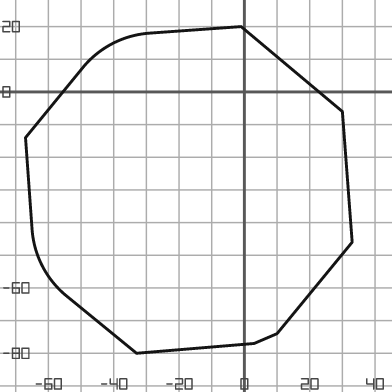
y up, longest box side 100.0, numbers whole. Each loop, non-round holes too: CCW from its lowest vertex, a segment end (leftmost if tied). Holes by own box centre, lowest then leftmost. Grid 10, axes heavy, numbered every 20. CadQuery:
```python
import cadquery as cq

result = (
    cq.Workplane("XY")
    .moveTo(-33.0, -80.0)
    .lineTo(3.0, -77.0)
    .lineTo(10.0, -74.0)
    .lineTo(33.0, -46.0)
    .lineTo(30.0, -6.0)
    .lineTo(-1.0, 20.0)
    .lineTo(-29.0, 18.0)
    .threePointArc((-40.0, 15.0), (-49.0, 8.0))
    .lineTo(-67.0, -14.0)
    .lineTo(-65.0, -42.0)
    .threePointArc((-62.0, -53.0), (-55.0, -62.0))
    .close()
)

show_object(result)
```